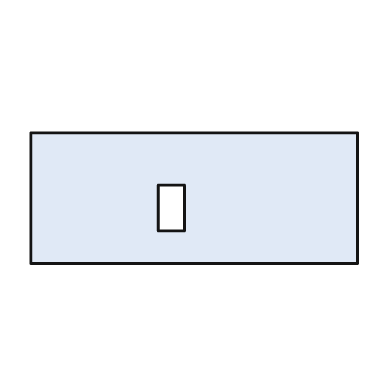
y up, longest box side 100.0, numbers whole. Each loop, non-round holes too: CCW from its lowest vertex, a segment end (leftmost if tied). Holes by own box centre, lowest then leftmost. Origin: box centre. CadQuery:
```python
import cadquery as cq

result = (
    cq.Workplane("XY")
    .moveTo(-50.0, -20.0)
    .lineTo(50.0, -20.0)
    .lineTo(50.0, 20.0)
    .lineTo(-50.0, 20.0)
    .close()
    .moveTo(-11.0, -10.0)
    .lineTo(-3.0, -10.0)
    .lineTo(-3.0, 4.0)
    .lineTo(-11.0, 4.0)
    .close()
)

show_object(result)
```